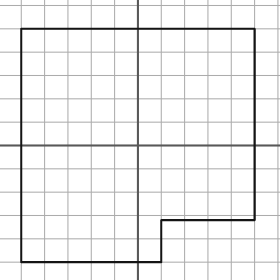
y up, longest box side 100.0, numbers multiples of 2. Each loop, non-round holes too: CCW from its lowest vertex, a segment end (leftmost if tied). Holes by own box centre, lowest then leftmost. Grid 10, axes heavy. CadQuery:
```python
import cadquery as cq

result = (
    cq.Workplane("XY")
    .moveTo(-50.0, -50.0)
    .lineTo(10.0, -50.0)
    .lineTo(10.0, -32.0)
    .lineTo(50.0, -32.0)
    .lineTo(50.0, 50.0)
    .lineTo(-50.0, 50.0)
    .close()
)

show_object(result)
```